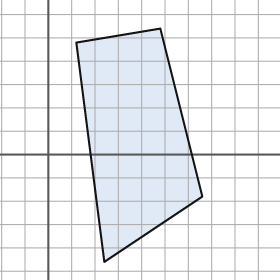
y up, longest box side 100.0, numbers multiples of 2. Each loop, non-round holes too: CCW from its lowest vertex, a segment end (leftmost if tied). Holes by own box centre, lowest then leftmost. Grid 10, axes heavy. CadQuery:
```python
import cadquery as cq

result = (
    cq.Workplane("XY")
    .moveTo(24.0, -46.0)
    .lineTo(66.0, -18.0)
    .lineTo(48.0, 54.0)
    .lineTo(12.0, 48.0)
    .close()
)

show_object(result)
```